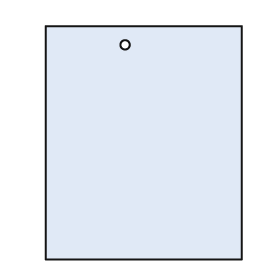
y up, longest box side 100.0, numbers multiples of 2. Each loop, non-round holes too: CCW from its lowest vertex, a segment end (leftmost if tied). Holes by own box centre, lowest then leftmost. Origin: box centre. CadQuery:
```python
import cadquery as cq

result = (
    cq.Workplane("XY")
    .moveTo(-42.0, -50.0)
    .lineTo(42.0, -50.0)
    .lineTo(42.0, 50.0)
    .lineTo(-42.0, 50.0)
    .close()
    .moveTo(-8.0, 42.0)
    .circle(2.0)
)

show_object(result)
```